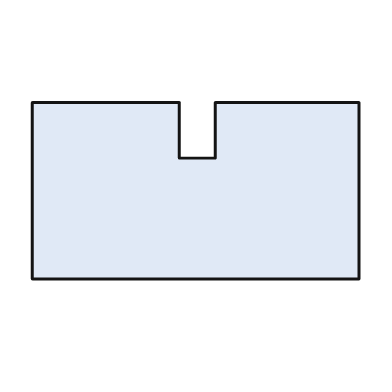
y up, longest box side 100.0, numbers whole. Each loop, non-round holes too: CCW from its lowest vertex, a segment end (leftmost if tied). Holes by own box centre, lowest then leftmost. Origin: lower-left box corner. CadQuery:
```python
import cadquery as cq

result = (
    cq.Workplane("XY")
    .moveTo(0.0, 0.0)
    .lineTo(100.0, 0.0)
    .lineTo(100.0, 54.0)
    .lineTo(56.0, 54.0)
    .lineTo(56.0, 37.0)
    .lineTo(45.0, 37.0)
    .lineTo(45.0, 54.0)
    .lineTo(0.0, 54.0)
    .close()
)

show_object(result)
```